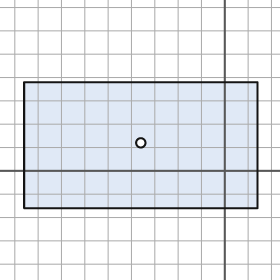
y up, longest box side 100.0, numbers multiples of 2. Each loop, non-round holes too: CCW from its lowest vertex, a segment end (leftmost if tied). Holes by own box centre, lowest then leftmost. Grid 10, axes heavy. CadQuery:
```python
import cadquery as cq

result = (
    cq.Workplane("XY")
    .moveTo(-86.0, -16.0)
    .lineTo(14.0, -16.0)
    .lineTo(14.0, 38.0)
    .lineTo(-86.0, 38.0)
    .close()
    .moveTo(-36.0, 12.0)
    .circle(2.0)
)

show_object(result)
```